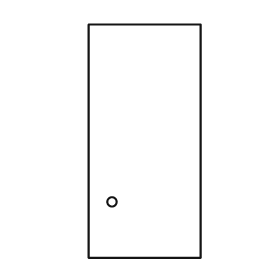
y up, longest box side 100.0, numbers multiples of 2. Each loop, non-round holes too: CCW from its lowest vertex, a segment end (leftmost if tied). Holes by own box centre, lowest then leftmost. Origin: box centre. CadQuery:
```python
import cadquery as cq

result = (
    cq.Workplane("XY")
    .moveTo(-24.0, -50.0)
    .lineTo(24.0, -50.0)
    .lineTo(24.0, 50.0)
    .lineTo(-24.0, 50.0)
    .close()
    .moveTo(-14.0, -26.0)
    .circle(2.0)
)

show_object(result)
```